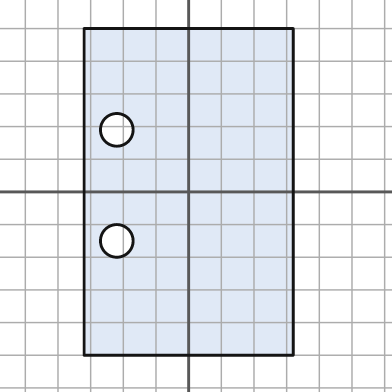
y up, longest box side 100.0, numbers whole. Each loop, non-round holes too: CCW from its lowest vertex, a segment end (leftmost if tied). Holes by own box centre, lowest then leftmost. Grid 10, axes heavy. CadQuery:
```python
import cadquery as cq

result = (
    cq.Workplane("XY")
    .moveTo(-32.0, -50.0)
    .lineTo(32.0, -50.0)
    .lineTo(32.0, 50.0)
    .lineTo(-32.0, 50.0)
    .close()
    .moveTo(-22.0, -15.0)
    .circle(5.0)
    .moveTo(-22.0, 19.0)
    .circle(5.0)
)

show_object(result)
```